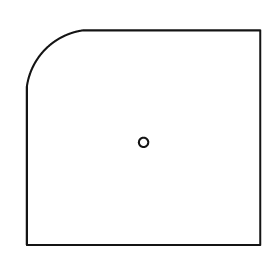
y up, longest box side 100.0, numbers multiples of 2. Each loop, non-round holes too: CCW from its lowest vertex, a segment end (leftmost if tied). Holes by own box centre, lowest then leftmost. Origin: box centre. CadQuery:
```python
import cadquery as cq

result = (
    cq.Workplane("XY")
    .moveTo(-50.0, -46.0)
    .lineTo(50.0, -46.0)
    .lineTo(50.0, 46.0)
    .lineTo(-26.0, 46.0)
    .threePointArc((-42.0, 38.0), (-50.0, 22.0))
    .close()
    .moveTo(0.0, -2.0)
    .circle(2.0)
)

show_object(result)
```